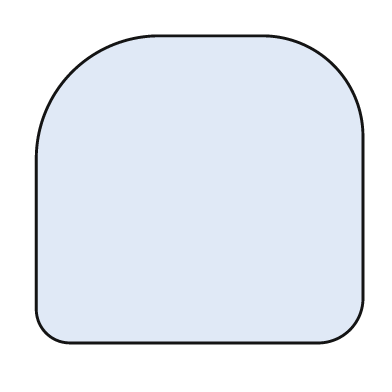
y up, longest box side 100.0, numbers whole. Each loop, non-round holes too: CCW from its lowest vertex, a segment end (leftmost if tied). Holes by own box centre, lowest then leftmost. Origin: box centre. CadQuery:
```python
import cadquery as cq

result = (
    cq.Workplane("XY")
    .moveTo(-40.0, -47.0)
    .lineTo(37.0, -47.0)
    .threePointArc((46.0, -43.0), (50.0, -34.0))
    .lineTo(50.0, 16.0)
    .threePointArc((41.0, 38.0), (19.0, 47.0))
    .lineTo(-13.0, 47.0)
    .threePointArc((-39.0, 36.0), (-50.0, 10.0))
    .lineTo(-50.0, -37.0)
    .threePointArc((-47.0, -44.0), (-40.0, -47.0))
    .close()
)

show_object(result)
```